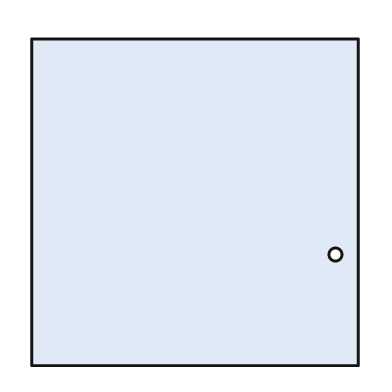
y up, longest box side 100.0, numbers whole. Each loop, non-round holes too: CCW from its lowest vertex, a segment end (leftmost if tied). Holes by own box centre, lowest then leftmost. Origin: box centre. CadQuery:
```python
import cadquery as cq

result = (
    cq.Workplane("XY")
    .moveTo(-50.0, -50.0)
    .lineTo(50.0, -50.0)
    .lineTo(50.0, 50.0)
    .lineTo(-50.0, 50.0)
    .close()
    .moveTo(43.0, -16.0)
    .circle(2.0)
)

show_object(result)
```